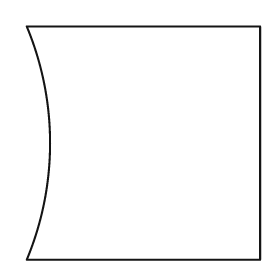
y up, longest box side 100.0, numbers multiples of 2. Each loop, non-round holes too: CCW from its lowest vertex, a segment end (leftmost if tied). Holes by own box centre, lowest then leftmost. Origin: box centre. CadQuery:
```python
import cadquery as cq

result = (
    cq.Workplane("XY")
    .moveTo(-50.0, -50.0)
    .lineTo(50.0, -50.0)
    .lineTo(50.0, 50.0)
    .lineTo(-50.0, 50.0)
    .threePointArc((-40.0, 0.0), (-50.0, -50.0))
    .close()
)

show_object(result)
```